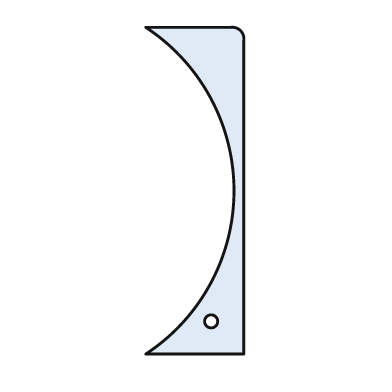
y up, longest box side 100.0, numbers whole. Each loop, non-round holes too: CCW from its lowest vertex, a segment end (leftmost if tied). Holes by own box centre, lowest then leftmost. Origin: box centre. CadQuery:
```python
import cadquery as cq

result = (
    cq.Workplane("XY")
    .moveTo(-15.0, -50.0)
    .lineTo(15.0, -50.0)
    .lineTo(15.0, 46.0)
    .threePointArc((14.0, 49.0), (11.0, 50.0))
    .lineTo(-15.0, 50.0)
    .threePointArc((12.0, 0.0), (-15.0, -50.0))
    .close()
    .moveTo(5.0, -40.0)
    .circle(2.0)
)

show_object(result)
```